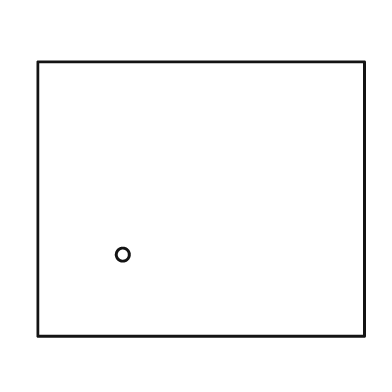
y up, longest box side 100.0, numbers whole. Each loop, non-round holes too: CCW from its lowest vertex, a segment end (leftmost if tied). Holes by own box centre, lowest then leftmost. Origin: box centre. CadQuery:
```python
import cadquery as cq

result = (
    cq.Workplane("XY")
    .moveTo(-50.0, -42.0)
    .lineTo(50.0, -42.0)
    .lineTo(50.0, 42.0)
    .lineTo(-50.0, 42.0)
    .close()
    .moveTo(-24.0, -17.0)
    .circle(2.0)
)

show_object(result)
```